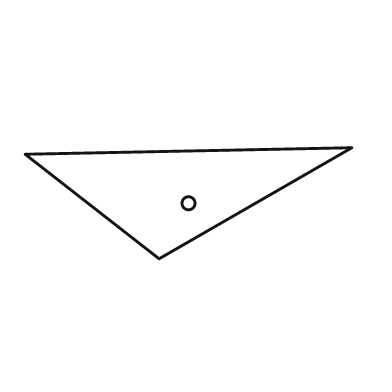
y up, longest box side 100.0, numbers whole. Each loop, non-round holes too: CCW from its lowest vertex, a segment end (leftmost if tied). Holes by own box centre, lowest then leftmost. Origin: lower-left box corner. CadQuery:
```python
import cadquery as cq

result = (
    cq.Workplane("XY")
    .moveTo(41.0, 0.0)
    .lineTo(100.0, 34.0)
    .lineTo(0.0, 32.0)
    .close()
    .moveTo(50.0, 17.0)
    .circle(2.0)
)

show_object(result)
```